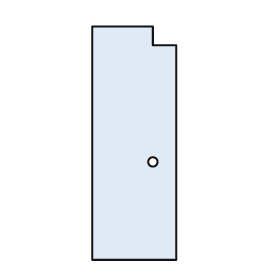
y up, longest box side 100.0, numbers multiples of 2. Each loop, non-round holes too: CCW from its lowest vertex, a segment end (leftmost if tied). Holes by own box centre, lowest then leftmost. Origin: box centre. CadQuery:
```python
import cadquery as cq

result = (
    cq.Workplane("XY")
    .moveTo(-18.0, -50.0)
    .lineTo(18.0, -50.0)
    .lineTo(18.0, 42.0)
    .lineTo(8.0, 42.0)
    .lineTo(8.0, 50.0)
    .lineTo(-18.0, 50.0)
    .close()
    .moveTo(8.0, -8.0)
    .circle(2.0)
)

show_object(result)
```